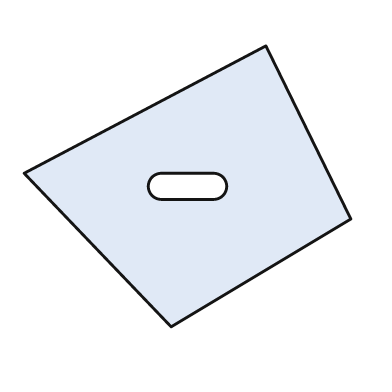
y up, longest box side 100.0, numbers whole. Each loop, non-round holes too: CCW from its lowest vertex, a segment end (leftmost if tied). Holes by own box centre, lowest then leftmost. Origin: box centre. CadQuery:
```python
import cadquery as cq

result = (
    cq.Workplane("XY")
    .moveTo(-5.0, -43.0)
    .lineTo(50.0, -10.0)
    .lineTo(24.0, 43.0)
    .lineTo(-50.0, 4.0)
    .close()
    .moveTo(-8.0, -4.0)
    .lineTo(8.0, -4.0)
    .threePointArc((12.0, 0.0), (8.0, 4.0))
    .lineTo(-8.0, 4.0)
    .threePointArc((-12.0, 0.0), (-8.0, -4.0))
    .close()
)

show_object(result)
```